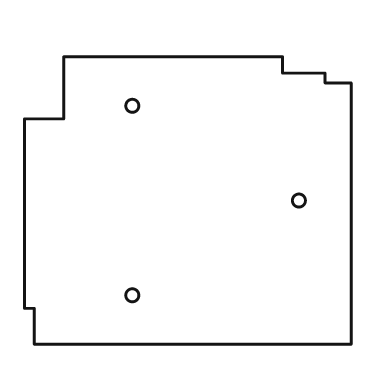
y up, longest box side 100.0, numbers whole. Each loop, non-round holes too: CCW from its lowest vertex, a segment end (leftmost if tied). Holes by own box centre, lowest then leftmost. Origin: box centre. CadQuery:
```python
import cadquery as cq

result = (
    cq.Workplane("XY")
    .moveTo(-47.0, -44.0)
    .lineTo(50.0, -44.0)
    .lineTo(50.0, 36.0)
    .lineTo(42.0, 36.0)
    .lineTo(42.0, 39.0)
    .lineTo(29.0, 39.0)
    .lineTo(29.0, 44.0)
    .lineTo(-38.0, 44.0)
    .lineTo(-38.0, 25.0)
    .lineTo(-50.0, 25.0)
    .lineTo(-50.0, -33.0)
    .lineTo(-47.0, -33.0)
    .close()
    .moveTo(-17.0, -29.0)
    .circle(2.0)
    .moveTo(34.0, 0.0)
    .circle(2.0)
    .moveTo(-17.0, 29.0)
    .circle(2.0)
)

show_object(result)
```